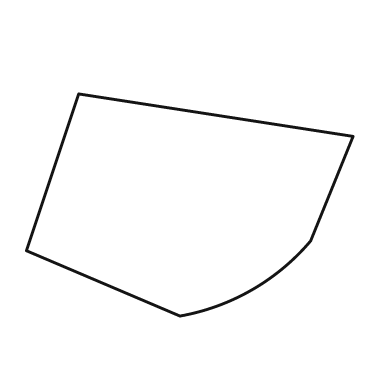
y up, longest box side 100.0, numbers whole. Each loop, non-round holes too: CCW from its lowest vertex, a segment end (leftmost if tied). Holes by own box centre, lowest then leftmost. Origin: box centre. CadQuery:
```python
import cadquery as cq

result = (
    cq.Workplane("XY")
    .moveTo(-3.0, -34.0)
    .threePointArc((19.0, -26.0), (37.0, -11.0))
    .lineTo(50.0, 21.0)
    .lineTo(-34.0, 34.0)
    .lineTo(-50.0, -14.0)
    .close()
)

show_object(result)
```